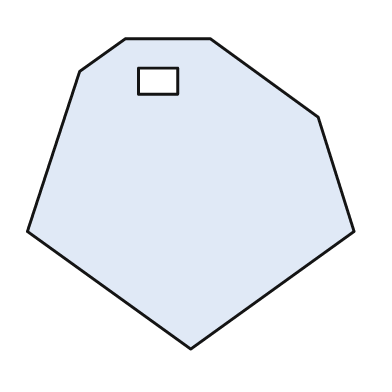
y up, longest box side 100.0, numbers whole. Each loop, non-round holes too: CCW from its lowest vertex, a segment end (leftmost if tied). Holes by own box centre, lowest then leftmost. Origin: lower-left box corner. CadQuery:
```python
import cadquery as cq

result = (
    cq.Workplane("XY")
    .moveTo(50.0, 0.0)
    .lineTo(100.0, 36.0)
    .lineTo(89.0, 71.0)
    .lineTo(56.0, 95.0)
    .lineTo(30.0, 95.0)
    .lineTo(16.0, 85.0)
    .lineTo(0.0, 36.0)
    .close()
    .moveTo(34.0, 78.0)
    .lineTo(46.0, 78.0)
    .lineTo(46.0, 86.0)
    .lineTo(34.0, 86.0)
    .close()
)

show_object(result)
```